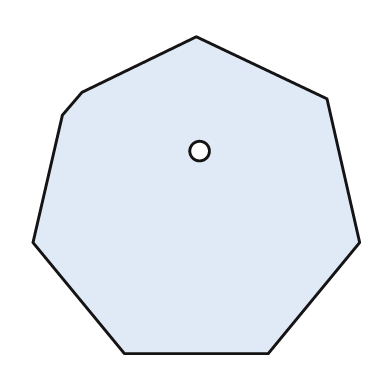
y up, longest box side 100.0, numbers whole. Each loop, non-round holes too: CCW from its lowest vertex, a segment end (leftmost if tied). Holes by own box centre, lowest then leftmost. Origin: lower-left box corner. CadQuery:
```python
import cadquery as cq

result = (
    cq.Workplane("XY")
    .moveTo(28.0, 0.0)
    .lineTo(72.0, 0.0)
    .lineTo(100.0, 34.0)
    .lineTo(90.0, 78.0)
    .lineTo(50.0, 97.0)
    .lineTo(15.0, 80.0)
    .lineTo(9.0, 73.0)
    .lineTo(0.0, 34.0)
    .close()
    .moveTo(51.0, 62.0)
    .circle(3.0)
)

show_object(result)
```